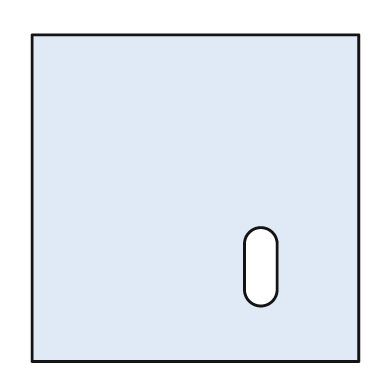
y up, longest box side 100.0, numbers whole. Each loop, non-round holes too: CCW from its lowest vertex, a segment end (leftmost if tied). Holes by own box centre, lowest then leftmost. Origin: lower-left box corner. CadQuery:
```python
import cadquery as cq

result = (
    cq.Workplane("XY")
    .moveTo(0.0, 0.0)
    .lineTo(100.0, 0.0)
    .lineTo(100.0, 100.0)
    .lineTo(0.0, 100.0)
    .close()
    .moveTo(65.0, 22.0)
    .threePointArc((70.0, 17.0), (75.0, 22.0))
    .lineTo(75.0, 36.0)
    .threePointArc((70.0, 41.0), (65.0, 36.0))
    .close()
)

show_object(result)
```